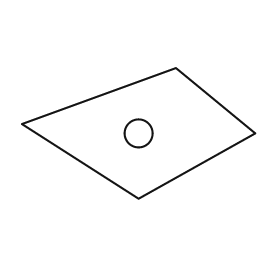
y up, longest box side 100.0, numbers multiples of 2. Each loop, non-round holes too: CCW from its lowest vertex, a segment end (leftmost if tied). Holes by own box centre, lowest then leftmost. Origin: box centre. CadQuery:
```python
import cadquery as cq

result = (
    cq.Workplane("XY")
    .moveTo(0.0, -28.0)
    .lineTo(50.0, 0.0)
    .lineTo(16.0, 28.0)
    .lineTo(-50.0, 4.0)
    .close()
    .moveTo(0.0, 0.0)
    .circle(6.0)
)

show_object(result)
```